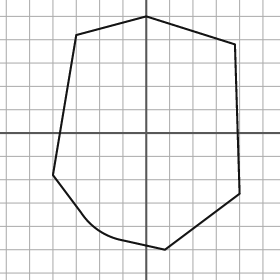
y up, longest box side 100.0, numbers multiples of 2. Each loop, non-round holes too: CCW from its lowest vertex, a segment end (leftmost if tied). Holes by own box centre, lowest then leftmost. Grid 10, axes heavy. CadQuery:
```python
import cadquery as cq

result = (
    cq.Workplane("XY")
    .moveTo(8.0, -50.0)
    .lineTo(40.0, -26.0)
    .lineTo(38.0, 38.0)
    .lineTo(0.0, 50.0)
    .lineTo(-30.0, 42.0)
    .lineTo(-40.0, -18.0)
    .lineTo(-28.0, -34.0)
    .threePointArc((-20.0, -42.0), (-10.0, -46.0))
    .close()
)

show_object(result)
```